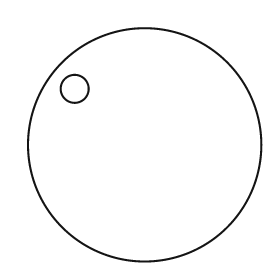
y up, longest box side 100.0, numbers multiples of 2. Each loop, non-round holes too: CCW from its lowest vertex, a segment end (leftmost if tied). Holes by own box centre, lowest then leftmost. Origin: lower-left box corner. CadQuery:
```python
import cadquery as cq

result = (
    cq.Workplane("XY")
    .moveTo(50.0, 50.0)
    .circle(50.0)
    .moveTo(20.0, 74.0)
    .circle(6.0)
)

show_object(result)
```